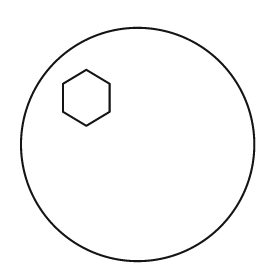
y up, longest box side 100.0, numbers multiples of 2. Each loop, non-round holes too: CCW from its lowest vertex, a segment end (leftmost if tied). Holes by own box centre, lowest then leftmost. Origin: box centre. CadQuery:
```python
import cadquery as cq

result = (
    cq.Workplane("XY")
    .moveTo(0.0, 0.0)
    .circle(50.0)
    .moveTo(-22.0, 8.0)
    .lineTo(-12.0, 14.0)
    .lineTo(-12.0, 26.0)
    .lineTo(-22.0, 32.0)
    .lineTo(-32.0, 26.0)
    .lineTo(-32.0, 14.0)
    .close()
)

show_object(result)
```